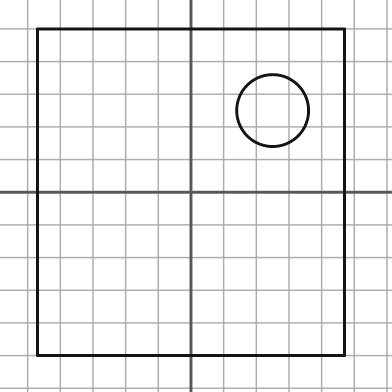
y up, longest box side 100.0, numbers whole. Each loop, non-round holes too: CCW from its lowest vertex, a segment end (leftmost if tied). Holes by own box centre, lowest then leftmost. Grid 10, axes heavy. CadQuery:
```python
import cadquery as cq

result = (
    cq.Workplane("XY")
    .moveTo(-47.0, -50.0)
    .lineTo(47.0, -50.0)
    .lineTo(47.0, 50.0)
    .lineTo(-47.0, 50.0)
    .close()
    .moveTo(25.0, 25.0)
    .circle(11.0)
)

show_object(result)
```